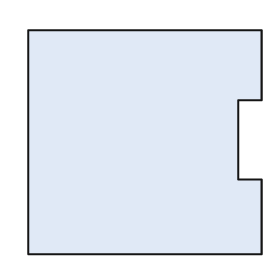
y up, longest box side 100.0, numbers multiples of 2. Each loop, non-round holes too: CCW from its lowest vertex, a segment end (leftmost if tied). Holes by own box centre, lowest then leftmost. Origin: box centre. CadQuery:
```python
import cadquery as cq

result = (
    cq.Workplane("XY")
    .moveTo(-50.0, -48.0)
    .lineTo(50.0, -48.0)
    .lineTo(50.0, -16.0)
    .lineTo(40.0, -16.0)
    .lineTo(40.0, 18.0)
    .lineTo(50.0, 18.0)
    .lineTo(50.0, 48.0)
    .lineTo(-50.0, 48.0)
    .close()
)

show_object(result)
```